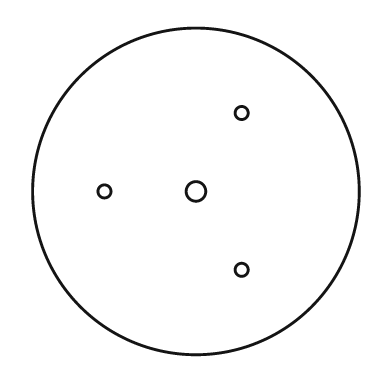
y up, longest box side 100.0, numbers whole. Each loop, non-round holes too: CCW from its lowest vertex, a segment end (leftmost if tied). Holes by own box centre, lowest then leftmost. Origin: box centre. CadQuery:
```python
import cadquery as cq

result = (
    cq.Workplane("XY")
    .moveTo(0.0, 0.0)
    .circle(50.0)
    .moveTo(14.0, -24.0)
    .circle(2.0)
    .moveTo(-28.0, 0.0)
    .circle(2.0)
    .moveTo(0.0, 0.0)
    .circle(3.0)
    .moveTo(14.0, 24.0)
    .circle(2.0)
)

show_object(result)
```